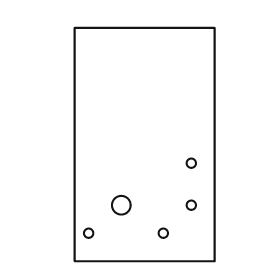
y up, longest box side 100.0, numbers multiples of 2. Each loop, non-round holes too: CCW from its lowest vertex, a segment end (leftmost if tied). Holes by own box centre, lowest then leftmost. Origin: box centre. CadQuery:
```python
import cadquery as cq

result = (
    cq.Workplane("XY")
    .moveTo(-30.0, -50.0)
    .lineTo(30.0, -50.0)
    .lineTo(30.0, 50.0)
    .lineTo(-30.0, 50.0)
    .close()
    .moveTo(-24.0, -38.0)
    .circle(2.0)
    .moveTo(8.0, -38.0)
    .circle(2.0)
    .moveTo(-10.0, -26.0)
    .circle(4.0)
    .moveTo(20.0, -26.0)
    .circle(2.0)
    .moveTo(20.0, -8.0)
    .circle(2.0)
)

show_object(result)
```